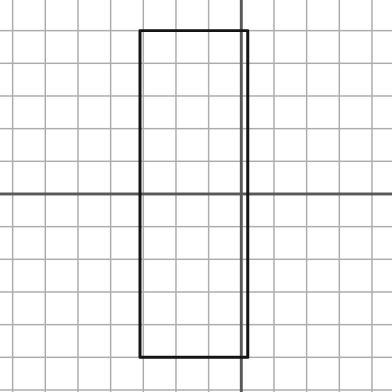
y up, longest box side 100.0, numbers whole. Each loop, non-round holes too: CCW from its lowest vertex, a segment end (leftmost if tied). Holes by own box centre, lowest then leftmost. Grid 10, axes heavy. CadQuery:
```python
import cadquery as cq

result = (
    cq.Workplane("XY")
    .moveTo(-31.0, -50.0)
    .lineTo(2.0, -50.0)
    .lineTo(2.0, 50.0)
    .lineTo(-31.0, 50.0)
    .close()
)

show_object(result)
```